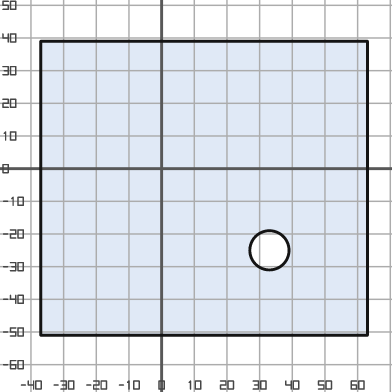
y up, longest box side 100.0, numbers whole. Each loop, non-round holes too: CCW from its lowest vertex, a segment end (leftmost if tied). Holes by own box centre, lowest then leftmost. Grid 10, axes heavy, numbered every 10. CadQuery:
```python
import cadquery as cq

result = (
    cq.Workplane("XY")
    .moveTo(-37.0, -51.0)
    .lineTo(63.0, -51.0)
    .lineTo(63.0, 39.0)
    .lineTo(-37.0, 39.0)
    .close()
    .moveTo(33.0, -25.0)
    .circle(6.0)
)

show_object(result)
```